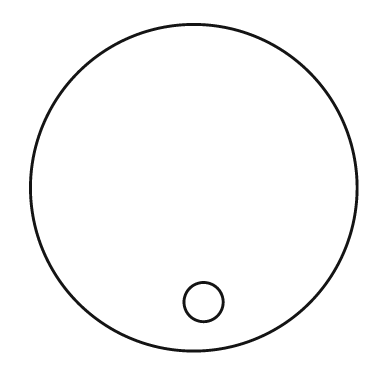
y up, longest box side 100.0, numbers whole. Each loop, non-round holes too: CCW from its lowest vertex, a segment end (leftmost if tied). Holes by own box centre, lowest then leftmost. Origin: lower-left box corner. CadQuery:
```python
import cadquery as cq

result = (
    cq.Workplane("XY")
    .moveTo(50.0, 50.0)
    .circle(50.0)
    .moveTo(53.0, 15.0)
    .circle(6.0)
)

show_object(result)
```